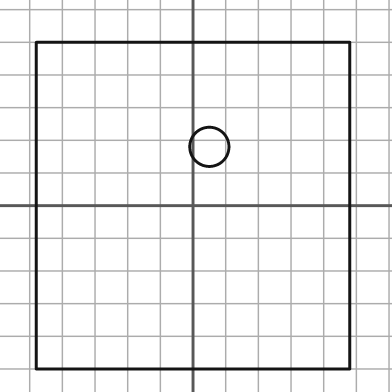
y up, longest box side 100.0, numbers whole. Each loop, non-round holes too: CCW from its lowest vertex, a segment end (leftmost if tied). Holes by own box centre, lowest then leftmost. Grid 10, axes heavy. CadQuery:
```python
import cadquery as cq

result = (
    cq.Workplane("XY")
    .moveTo(-48.0, -50.0)
    .lineTo(48.0, -50.0)
    .lineTo(48.0, 50.0)
    .lineTo(-48.0, 50.0)
    .close()
    .moveTo(5.0, 18.0)
    .circle(6.0)
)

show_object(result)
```